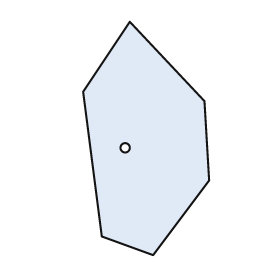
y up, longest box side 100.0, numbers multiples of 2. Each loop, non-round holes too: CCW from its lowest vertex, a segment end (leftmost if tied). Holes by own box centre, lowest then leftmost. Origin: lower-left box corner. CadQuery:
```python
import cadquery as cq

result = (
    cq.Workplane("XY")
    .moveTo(30.0, 0.0)
    .lineTo(54.0, 32.0)
    .lineTo(52.0, 66.0)
    .lineTo(20.0, 100.0)
    .lineTo(0.0, 70.0)
    .lineTo(8.0, 8.0)
    .close()
    .moveTo(18.0, 46.0)
    .circle(2.0)
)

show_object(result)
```